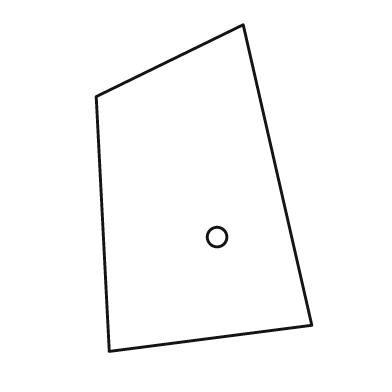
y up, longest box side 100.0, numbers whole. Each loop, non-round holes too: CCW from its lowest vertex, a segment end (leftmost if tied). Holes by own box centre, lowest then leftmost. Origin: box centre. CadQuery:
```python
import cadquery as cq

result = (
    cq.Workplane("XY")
    .moveTo(-29.0, -50.0)
    .lineTo(33.0, -42.0)
    .lineTo(12.0, 50.0)
    .lineTo(-33.0, 28.0)
    .close()
    .moveTo(4.0, -15.0)
    .circle(3.0)
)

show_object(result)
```